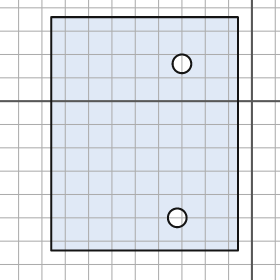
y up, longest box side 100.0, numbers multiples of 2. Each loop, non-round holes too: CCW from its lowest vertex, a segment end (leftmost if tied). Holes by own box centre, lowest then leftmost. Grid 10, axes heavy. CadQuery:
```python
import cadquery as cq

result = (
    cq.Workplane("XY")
    .moveTo(-86.0, -64.0)
    .lineTo(-6.0, -64.0)
    .lineTo(-6.0, 36.0)
    .lineTo(-86.0, 36.0)
    .close()
    .moveTo(-32.0, -50.0)
    .circle(4.0)
    .moveTo(-30.0, 16.0)
    .circle(4.0)
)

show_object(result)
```